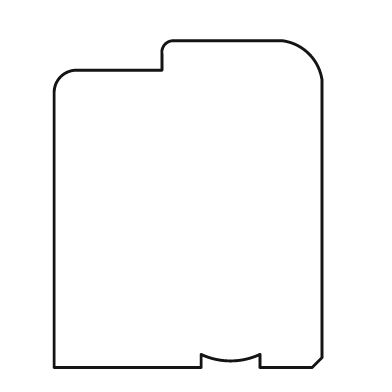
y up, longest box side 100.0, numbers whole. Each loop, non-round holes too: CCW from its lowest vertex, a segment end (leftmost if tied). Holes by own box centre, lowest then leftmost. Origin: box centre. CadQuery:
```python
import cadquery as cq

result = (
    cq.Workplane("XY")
    .moveTo(-41.0, -50.0)
    .lineTo(4.0, -50.0)
    .lineTo(4.0, -46.0)
    .threePointArc((13.0, -48.0), (22.0, -46.0))
    .lineTo(22.0, -50.0)
    .lineTo(38.0, -50.0)
    .lineTo(41.0, -47.0)
    .lineTo(41.0, 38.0)
    .threePointArc((37.0, 46.0), (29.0, 50.0))
    .lineTo(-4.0, 50.0)
    .threePointArc((-7.0, 49.0), (-8.0, 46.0))
    .lineTo(-8.0, 41.0)
    .lineTo(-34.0, 41.0)
    .threePointArc((-39.0, 39.0), (-41.0, 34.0))
    .close()
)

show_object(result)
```